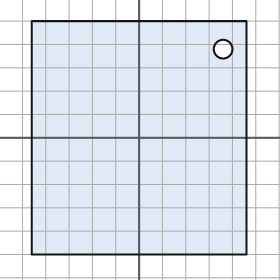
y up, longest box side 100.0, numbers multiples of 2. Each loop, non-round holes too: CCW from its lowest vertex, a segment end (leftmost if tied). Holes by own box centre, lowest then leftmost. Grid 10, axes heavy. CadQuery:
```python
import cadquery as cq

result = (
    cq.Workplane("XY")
    .moveTo(-46.0, -50.0)
    .lineTo(46.0, -50.0)
    .lineTo(46.0, 50.0)
    .lineTo(-46.0, 50.0)
    .close()
    .moveTo(36.0, 38.0)
    .circle(4.0)
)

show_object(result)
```